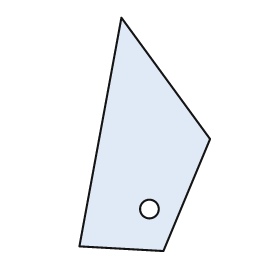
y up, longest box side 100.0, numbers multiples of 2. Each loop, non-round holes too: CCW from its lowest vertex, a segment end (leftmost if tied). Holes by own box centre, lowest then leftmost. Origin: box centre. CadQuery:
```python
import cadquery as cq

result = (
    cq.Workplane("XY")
    .moveTo(8.0, -50.0)
    .lineTo(28.0, -2.0)
    .lineTo(-10.0, 50.0)
    .lineTo(-28.0, -48.0)
    .close()
    .moveTo(2.0, -32.0)
    .circle(4.0)
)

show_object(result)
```